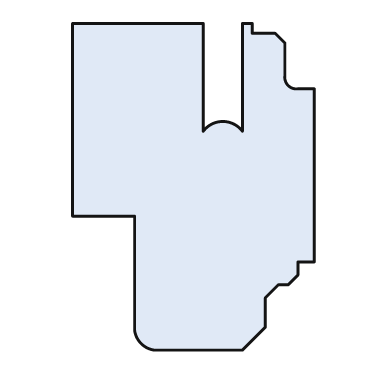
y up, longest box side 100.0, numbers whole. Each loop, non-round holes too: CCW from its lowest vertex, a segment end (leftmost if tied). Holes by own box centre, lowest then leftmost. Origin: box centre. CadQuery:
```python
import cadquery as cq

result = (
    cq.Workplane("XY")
    .moveTo(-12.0, -50.0)
    .lineTo(15.0, -50.0)
    .lineTo(22.0, -43.0)
    .lineTo(22.0, -34.0)
    .lineTo(26.0, -30.0)
    .lineTo(29.0, -30.0)
    .lineTo(32.0, -27.0)
    .lineTo(32.0, -23.0)
    .lineTo(37.0, -23.0)
    .lineTo(37.0, 30.0)
    .lineTo(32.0, 30.0)
    .threePointArc((29.0, 31.0), (28.0, 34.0))
    .lineTo(28.0, 44.0)
    .lineTo(25.0, 47.0)
    .lineTo(18.0, 47.0)
    .lineTo(18.0, 50.0)
    .lineTo(15.0, 50.0)
    .lineTo(15.0, 17.0)
    .threePointArc((9.0, 20.0), (3.0, 17.0))
    .lineTo(3.0, 50.0)
    .lineTo(-37.0, 50.0)
    .lineTo(-37.0, -9.0)
    .lineTo(-18.0, -9.0)
    .lineTo(-18.0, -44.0)
    .threePointArc((-16.0, -48.0), (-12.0, -50.0))
    .close()
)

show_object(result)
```